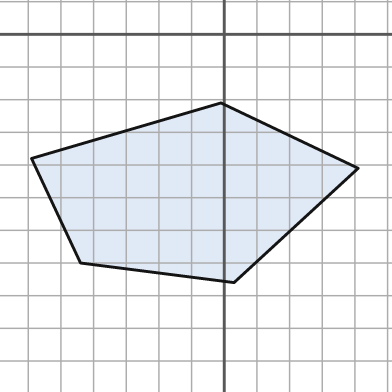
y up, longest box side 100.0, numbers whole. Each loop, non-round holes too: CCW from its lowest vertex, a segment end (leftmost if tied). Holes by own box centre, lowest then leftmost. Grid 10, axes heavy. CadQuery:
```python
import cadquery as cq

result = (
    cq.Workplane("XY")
    .moveTo(3.0, -76.0)
    .lineTo(41.0, -41.0)
    .lineTo(-1.0, -21.0)
    .lineTo(-59.0, -38.0)
    .lineTo(-44.0, -70.0)
    .close()
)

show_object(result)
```